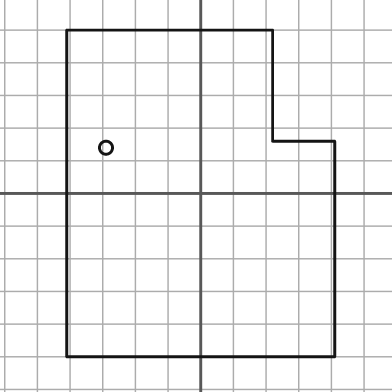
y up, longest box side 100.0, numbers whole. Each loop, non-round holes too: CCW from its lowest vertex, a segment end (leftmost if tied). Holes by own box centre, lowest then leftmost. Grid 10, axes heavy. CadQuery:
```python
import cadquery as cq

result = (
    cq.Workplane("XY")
    .moveTo(-41.0, -50.0)
    .lineTo(41.0, -50.0)
    .lineTo(41.0, 16.0)
    .lineTo(22.0, 16.0)
    .lineTo(22.0, 50.0)
    .lineTo(-41.0, 50.0)
    .close()
    .moveTo(-29.0, 14.0)
    .circle(2.0)
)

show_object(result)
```